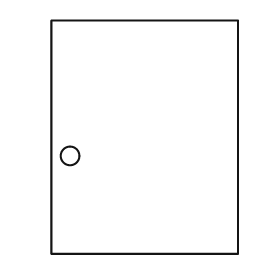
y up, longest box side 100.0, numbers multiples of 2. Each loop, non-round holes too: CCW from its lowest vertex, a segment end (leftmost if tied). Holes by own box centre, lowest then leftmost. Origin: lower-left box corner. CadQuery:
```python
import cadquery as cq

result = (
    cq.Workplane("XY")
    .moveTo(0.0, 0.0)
    .lineTo(80.0, 0.0)
    .lineTo(80.0, 100.0)
    .lineTo(0.0, 100.0)
    .close()
    .moveTo(8.0, 42.0)
    .circle(4.0)
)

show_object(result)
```